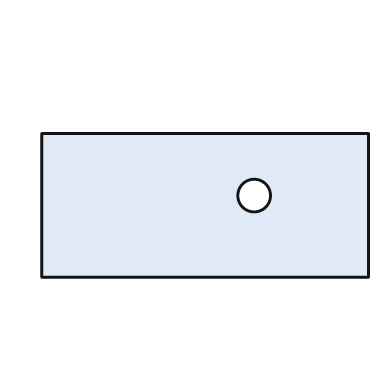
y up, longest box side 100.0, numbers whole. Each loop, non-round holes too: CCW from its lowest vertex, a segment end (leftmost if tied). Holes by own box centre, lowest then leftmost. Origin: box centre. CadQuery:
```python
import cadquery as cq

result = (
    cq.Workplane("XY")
    .moveTo(-50.0, -22.0)
    .lineTo(50.0, -22.0)
    .lineTo(50.0, 22.0)
    .lineTo(-50.0, 22.0)
    .close()
    .moveTo(15.0, 3.0)
    .circle(5.0)
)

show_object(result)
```